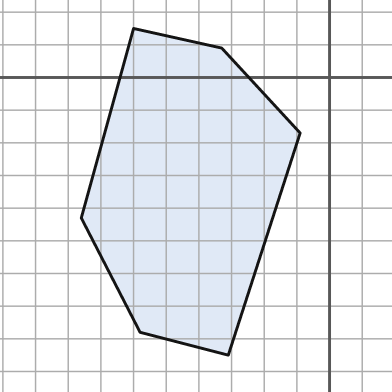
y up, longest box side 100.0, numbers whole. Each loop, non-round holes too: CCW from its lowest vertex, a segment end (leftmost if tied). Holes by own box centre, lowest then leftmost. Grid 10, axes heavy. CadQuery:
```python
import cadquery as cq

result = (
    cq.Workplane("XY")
    .moveTo(-31.0, -85.0)
    .lineTo(-9.0, -17.0)
    .lineTo(-33.0, 9.0)
    .lineTo(-60.0, 15.0)
    .lineTo(-76.0, -43.0)
    .lineTo(-58.0, -78.0)
    .close()
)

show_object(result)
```